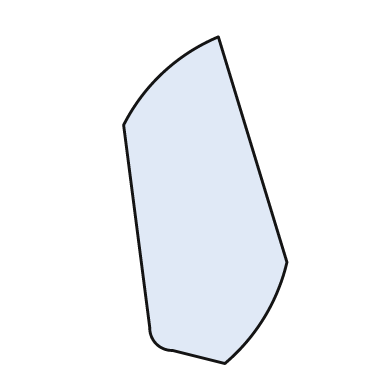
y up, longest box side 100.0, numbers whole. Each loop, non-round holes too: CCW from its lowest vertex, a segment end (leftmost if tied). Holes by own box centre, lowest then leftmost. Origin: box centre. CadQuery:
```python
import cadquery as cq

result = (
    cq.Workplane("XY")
    .moveTo(6.0, -50.0)
    .threePointArc((18.0, -36.0), (25.0, -19.0))
    .lineTo(4.0, 50.0)
    .threePointArc((-13.0, 39.0), (-25.0, 23.0))
    .lineTo(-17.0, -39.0)
    .threePointArc((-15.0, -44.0), (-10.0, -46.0))
    .close()
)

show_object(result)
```